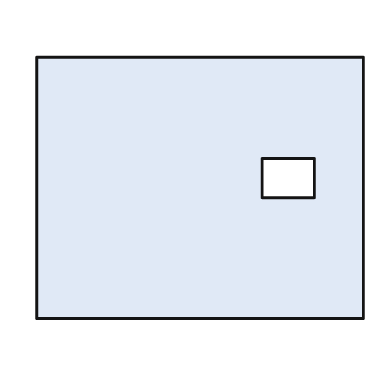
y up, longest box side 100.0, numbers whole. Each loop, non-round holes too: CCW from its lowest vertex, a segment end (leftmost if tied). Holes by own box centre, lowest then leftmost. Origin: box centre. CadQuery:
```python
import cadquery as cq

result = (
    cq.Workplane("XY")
    .moveTo(-50.0, -40.0)
    .lineTo(50.0, -40.0)
    .lineTo(50.0, 40.0)
    .lineTo(-50.0, 40.0)
    .close()
    .moveTo(19.0, -3.0)
    .lineTo(35.0, -3.0)
    .lineTo(35.0, 9.0)
    .lineTo(19.0, 9.0)
    .close()
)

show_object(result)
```